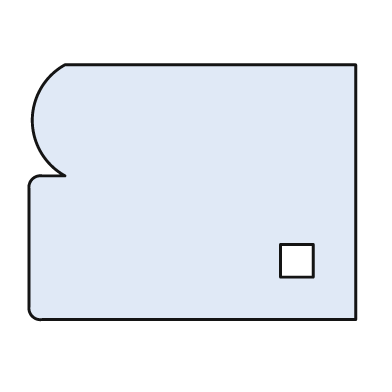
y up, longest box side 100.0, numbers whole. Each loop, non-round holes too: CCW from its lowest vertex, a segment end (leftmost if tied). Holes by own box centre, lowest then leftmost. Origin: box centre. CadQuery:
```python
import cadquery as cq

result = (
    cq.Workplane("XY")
    .moveTo(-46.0, -39.0)
    .lineTo(50.0, -39.0)
    .lineTo(50.0, 39.0)
    .lineTo(-39.0, 39.0)
    .threePointArc((-49.0, 22.0), (-39.0, 5.0))
    .lineTo(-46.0, 5.0)
    .threePointArc((-49.0, 4.0), (-50.0, 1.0))
    .lineTo(-50.0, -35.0)
    .threePointArc((-49.0, -38.0), (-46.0, -39.0))
    .close()
    .moveTo(27.0, -26.0)
    .lineTo(37.0, -26.0)
    .lineTo(37.0, -16.0)
    .lineTo(27.0, -16.0)
    .close()
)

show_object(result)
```